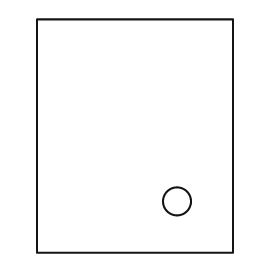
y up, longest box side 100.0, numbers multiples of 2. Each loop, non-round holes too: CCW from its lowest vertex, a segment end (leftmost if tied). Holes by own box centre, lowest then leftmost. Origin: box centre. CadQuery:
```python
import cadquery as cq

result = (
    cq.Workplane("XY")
    .moveTo(-42.0, -50.0)
    .lineTo(42.0, -50.0)
    .lineTo(42.0, 50.0)
    .lineTo(-42.0, 50.0)
    .close()
    .moveTo(18.0, -28.0)
    .circle(6.0)
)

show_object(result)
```